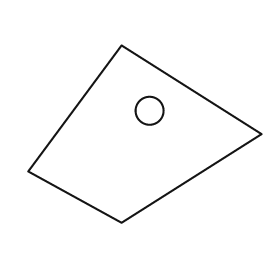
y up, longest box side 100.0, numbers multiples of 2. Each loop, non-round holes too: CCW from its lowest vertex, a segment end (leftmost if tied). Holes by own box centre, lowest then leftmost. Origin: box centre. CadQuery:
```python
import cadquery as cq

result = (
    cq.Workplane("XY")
    .moveTo(-10.0, -38.0)
    .lineTo(50.0, 0.0)
    .lineTo(-10.0, 38.0)
    .lineTo(-50.0, -16.0)
    .close()
    .moveTo(2.0, 10.0)
    .circle(6.0)
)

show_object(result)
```